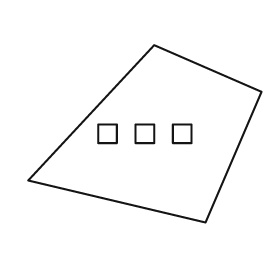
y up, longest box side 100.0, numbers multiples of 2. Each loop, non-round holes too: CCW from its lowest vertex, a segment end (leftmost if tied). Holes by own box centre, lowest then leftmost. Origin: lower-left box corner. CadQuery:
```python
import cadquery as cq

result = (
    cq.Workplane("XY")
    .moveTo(76.0, 0.0)
    .lineTo(100.0, 56.0)
    .lineTo(54.0, 76.0)
    .lineTo(0.0, 18.0)
    .close()
    .moveTo(30.0, 34.0)
    .lineTo(38.0, 34.0)
    .lineTo(38.0, 42.0)
    .lineTo(30.0, 42.0)
    .close()
    .moveTo(46.0, 34.0)
    .lineTo(54.0, 34.0)
    .lineTo(54.0, 42.0)
    .lineTo(46.0, 42.0)
    .close()
    .moveTo(62.0, 34.0)
    .lineTo(70.0, 34.0)
    .lineTo(70.0, 42.0)
    .lineTo(62.0, 42.0)
    .close()
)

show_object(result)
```